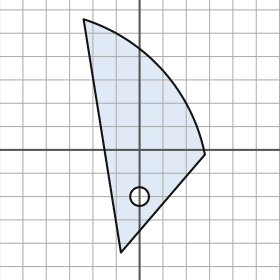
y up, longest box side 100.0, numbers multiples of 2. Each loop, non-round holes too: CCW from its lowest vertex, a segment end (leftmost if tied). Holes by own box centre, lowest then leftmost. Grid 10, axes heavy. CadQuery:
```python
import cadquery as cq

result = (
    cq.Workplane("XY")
    .moveTo(-8.0, -44.0)
    .lineTo(28.0, -2.0)
    .threePointArc((10.0, 34.0), (-24.0, 56.0))
    .close()
    .moveTo(0.0, -20.0)
    .circle(4.0)
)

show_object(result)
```